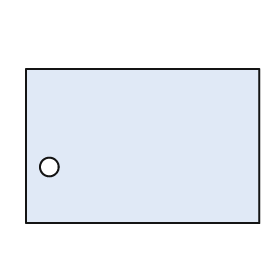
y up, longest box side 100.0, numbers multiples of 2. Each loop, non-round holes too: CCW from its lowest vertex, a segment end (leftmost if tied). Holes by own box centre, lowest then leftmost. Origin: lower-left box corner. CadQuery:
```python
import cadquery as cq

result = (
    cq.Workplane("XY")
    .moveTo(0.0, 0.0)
    .lineTo(100.0, 0.0)
    .lineTo(100.0, 66.0)
    .lineTo(0.0, 66.0)
    .close()
    .moveTo(10.0, 24.0)
    .circle(4.0)
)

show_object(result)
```